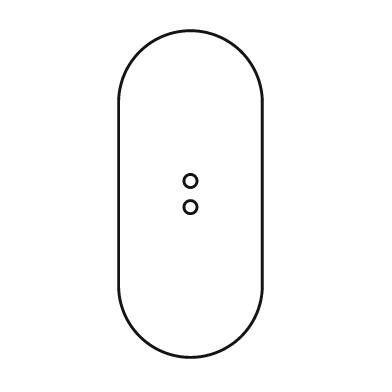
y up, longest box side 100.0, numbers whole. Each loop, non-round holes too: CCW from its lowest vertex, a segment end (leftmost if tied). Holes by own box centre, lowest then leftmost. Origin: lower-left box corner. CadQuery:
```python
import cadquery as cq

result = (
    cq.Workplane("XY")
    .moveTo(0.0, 22.0)
    .threePointArc((22.0, 0.0), (44.0, 22.0))
    .lineTo(44.0, 78.0)
    .threePointArc((22.0, 100.0), (0.0, 78.0))
    .close()
    .moveTo(22.0, 46.0)
    .circle(2.0)
    .moveTo(22.0, 54.0)
    .circle(2.0)
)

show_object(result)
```